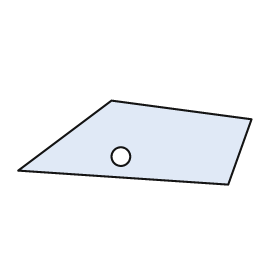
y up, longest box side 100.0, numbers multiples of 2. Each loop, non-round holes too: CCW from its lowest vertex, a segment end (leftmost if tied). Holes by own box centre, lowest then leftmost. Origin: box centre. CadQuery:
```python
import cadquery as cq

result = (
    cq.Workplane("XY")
    .moveTo(40.0, -18.0)
    .lineTo(50.0, 10.0)
    .lineTo(-10.0, 18.0)
    .lineTo(-50.0, -12.0)
    .close()
    .moveTo(-6.0, -6.0)
    .circle(4.0)
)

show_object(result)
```